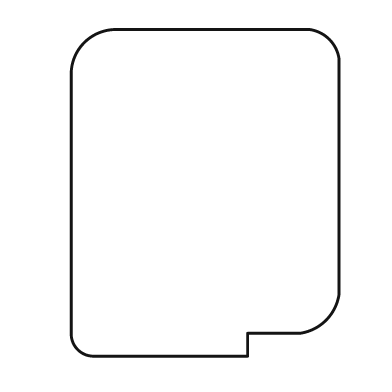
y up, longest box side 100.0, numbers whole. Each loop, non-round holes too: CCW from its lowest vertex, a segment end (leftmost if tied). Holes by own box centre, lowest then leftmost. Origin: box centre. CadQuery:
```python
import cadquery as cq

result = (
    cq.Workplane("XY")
    .moveTo(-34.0, -50.0)
    .lineTo(13.0, -50.0)
    .lineTo(13.0, -43.0)
    .lineTo(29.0, -43.0)
    .threePointArc((37.0, -39.0), (41.0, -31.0))
    .lineTo(41.0, 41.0)
    .threePointArc((38.0, 47.0), (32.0, 50.0))
    .lineTo(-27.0, 50.0)
    .threePointArc((-37.0, 46.0), (-41.0, 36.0))
    .lineTo(-41.0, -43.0)
    .threePointArc((-39.0, -48.0), (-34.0, -50.0))
    .close()
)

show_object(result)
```